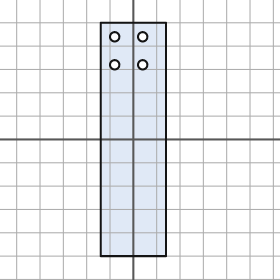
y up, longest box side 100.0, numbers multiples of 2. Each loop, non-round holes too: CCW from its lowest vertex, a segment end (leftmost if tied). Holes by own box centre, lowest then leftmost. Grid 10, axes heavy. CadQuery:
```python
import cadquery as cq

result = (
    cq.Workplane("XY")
    .moveTo(-14.0, -50.0)
    .lineTo(14.0, -50.0)
    .lineTo(14.0, 50.0)
    .lineTo(-14.0, 50.0)
    .close()
    .moveTo(-8.0, 32.0)
    .circle(2.0)
    .moveTo(4.0, 32.0)
    .circle(2.0)
    .moveTo(-8.0, 44.0)
    .circle(2.0)
    .moveTo(4.0, 44.0)
    .circle(2.0)
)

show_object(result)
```